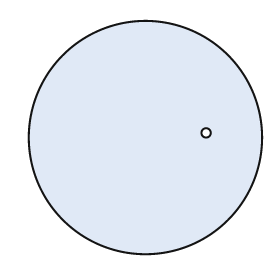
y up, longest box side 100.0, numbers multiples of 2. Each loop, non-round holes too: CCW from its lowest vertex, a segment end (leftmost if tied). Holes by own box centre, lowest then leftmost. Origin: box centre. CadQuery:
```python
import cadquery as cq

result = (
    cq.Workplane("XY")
    .moveTo(0.0, 0.0)
    .circle(50.0)
    .moveTo(26.0, 2.0)
    .circle(2.0)
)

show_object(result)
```